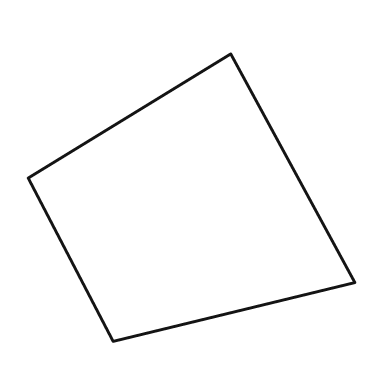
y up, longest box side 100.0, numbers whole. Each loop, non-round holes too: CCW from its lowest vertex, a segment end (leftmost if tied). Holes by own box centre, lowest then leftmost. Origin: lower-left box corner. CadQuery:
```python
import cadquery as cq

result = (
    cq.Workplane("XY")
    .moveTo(26.0, 0.0)
    .lineTo(100.0, 18.0)
    .lineTo(62.0, 88.0)
    .lineTo(0.0, 50.0)
    .close()
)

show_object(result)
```